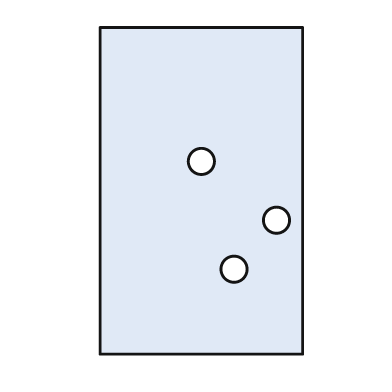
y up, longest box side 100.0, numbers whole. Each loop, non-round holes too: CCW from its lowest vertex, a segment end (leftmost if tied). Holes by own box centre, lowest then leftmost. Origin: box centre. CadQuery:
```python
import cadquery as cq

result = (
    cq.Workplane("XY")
    .moveTo(-31.0, -50.0)
    .lineTo(31.0, -50.0)
    .lineTo(31.0, 50.0)
    .lineTo(-31.0, 50.0)
    .close()
    .moveTo(10.0, -24.0)
    .circle(4.0)
    .moveTo(23.0, -9.0)
    .circle(4.0)
    .moveTo(0.0, 9.0)
    .circle(4.0)
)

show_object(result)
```